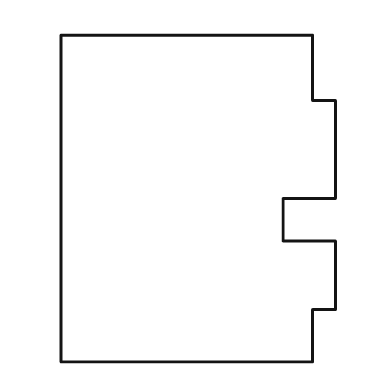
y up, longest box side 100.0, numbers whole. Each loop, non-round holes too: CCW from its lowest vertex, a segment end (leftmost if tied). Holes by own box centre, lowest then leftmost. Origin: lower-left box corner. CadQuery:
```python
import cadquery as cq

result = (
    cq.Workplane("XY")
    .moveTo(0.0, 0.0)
    .lineTo(77.0, 0.0)
    .lineTo(77.0, 16.0)
    .lineTo(84.0, 16.0)
    .lineTo(84.0, 37.0)
    .lineTo(68.0, 37.0)
    .lineTo(68.0, 50.0)
    .lineTo(84.0, 50.0)
    .lineTo(84.0, 80.0)
    .lineTo(77.0, 80.0)
    .lineTo(77.0, 100.0)
    .lineTo(0.0, 100.0)
    .close()
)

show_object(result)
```